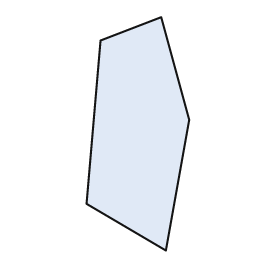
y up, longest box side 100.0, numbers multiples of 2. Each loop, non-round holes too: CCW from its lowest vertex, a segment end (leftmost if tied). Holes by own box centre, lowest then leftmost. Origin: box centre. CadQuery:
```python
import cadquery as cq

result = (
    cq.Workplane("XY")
    .moveTo(12.0, -50.0)
    .lineTo(22.0, 6.0)
    .lineTo(10.0, 50.0)
    .lineTo(-16.0, 40.0)
    .lineTo(-22.0, -30.0)
    .close()
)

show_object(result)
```